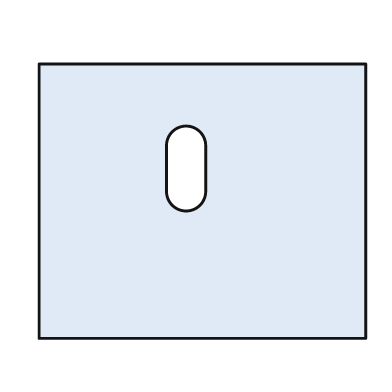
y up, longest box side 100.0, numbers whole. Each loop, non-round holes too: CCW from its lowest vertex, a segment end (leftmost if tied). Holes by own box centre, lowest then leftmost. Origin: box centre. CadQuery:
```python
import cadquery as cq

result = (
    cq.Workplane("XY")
    .moveTo(-50.0, -42.0)
    .lineTo(50.0, -42.0)
    .lineTo(50.0, 42.0)
    .lineTo(-50.0, 42.0)
    .close()
    .moveTo(-11.0, 3.0)
    .threePointArc((-5.0, -3.0), (1.0, 3.0))
    .lineTo(1.0, 17.0)
    .threePointArc((-5.0, 23.0), (-11.0, 17.0))
    .close()
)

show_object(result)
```